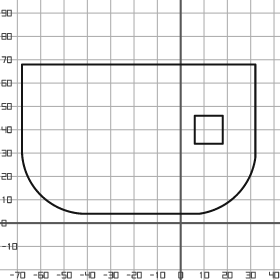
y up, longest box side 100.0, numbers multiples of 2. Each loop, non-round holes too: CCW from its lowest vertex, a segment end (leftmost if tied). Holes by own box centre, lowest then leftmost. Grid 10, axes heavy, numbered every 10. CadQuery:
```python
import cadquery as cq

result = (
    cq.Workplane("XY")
    .moveTo(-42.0, 4.0)
    .lineTo(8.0, 4.0)
    .threePointArc((24.0, 12.0), (32.0, 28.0))
    .lineTo(32.0, 68.0)
    .lineTo(-68.0, 68.0)
    .lineTo(-68.0, 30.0)
    .threePointArc((-60.0, 12.0), (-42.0, 4.0))
    .close()
    .moveTo(6.0, 34.0)
    .lineTo(18.0, 34.0)
    .lineTo(18.0, 46.0)
    .lineTo(6.0, 46.0)
    .close()
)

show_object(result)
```